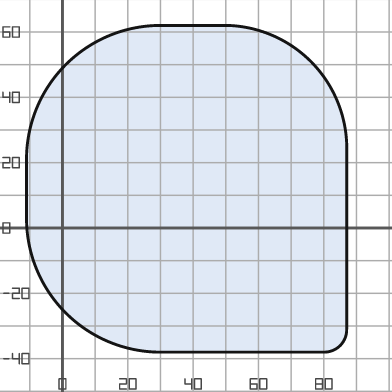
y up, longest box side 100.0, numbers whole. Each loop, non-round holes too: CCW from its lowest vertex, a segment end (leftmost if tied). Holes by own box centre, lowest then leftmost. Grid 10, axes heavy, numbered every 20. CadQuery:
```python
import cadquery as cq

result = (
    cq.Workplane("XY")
    .moveTo(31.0, -38.0)
    .lineTo(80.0, -38.0)
    .threePointArc((85.0, -36.0), (87.0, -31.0))
    .lineTo(87.0, 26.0)
    .threePointArc((76.0, 51.0), (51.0, 62.0))
    .lineTo(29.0, 62.0)
    .threePointArc((1.0, 50.0), (-11.0, 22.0))
    .lineTo(-11.0, 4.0)
    .threePointArc((1.0, -26.0), (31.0, -38.0))
    .close()
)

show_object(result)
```